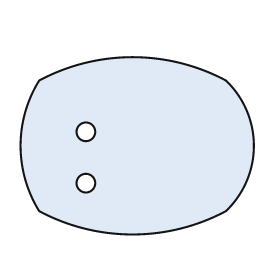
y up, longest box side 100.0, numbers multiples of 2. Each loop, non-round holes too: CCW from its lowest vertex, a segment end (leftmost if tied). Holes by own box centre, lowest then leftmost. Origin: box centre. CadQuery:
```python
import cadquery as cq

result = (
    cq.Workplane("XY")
    .moveTo(-42.0, -28.0)
    .threePointArc((-2.0, -38.0), (38.0, -28.0))
    .threePointArc((50.0, 0.0), (38.0, 28.0))
    .threePointArc((-2.0, 38.0), (-42.0, 28.0))
    .threePointArc((-50.0, 0.0), (-42.0, -28.0))
    .close()
    .moveTo(-22.0, -16.0)
    .circle(4.0)
    .moveTo(-22.0, 6.0)
    .circle(4.0)
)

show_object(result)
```